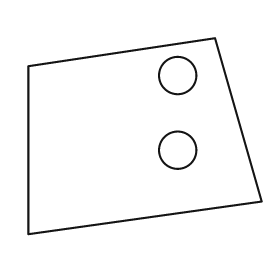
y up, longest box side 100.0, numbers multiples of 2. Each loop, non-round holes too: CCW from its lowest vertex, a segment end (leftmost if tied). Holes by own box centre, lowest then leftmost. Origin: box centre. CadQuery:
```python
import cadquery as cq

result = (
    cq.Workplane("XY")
    .moveTo(-50.0, -42.0)
    .lineTo(50.0, -28.0)
    .lineTo(30.0, 42.0)
    .lineTo(-50.0, 30.0)
    .close()
    .moveTo(14.0, -6.0)
    .circle(8.0)
    .moveTo(14.0, 26.0)
    .circle(8.0)
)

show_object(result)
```